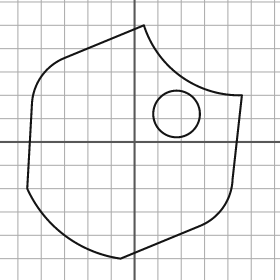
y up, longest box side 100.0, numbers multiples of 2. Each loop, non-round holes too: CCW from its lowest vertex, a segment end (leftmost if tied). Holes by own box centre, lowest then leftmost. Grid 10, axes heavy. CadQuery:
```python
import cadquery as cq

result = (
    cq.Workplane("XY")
    .moveTo(-6.0, -50.0)
    .lineTo(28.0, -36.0)
    .threePointArc((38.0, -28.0), (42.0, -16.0))
    .lineTo(46.0, 20.0)
    .threePointArc((20.0, 28.0), (4.0, 50.0))
    .lineTo(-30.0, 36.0)
    .threePointArc((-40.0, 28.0), (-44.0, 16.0))
    .lineTo(-46.0, -20.0)
    .threePointArc((-30.0, -40.0), (-6.0, -50.0))
    .close()
    .moveTo(18.0, 12.0)
    .circle(10.0)
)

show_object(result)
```